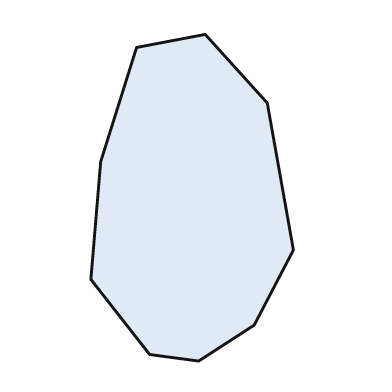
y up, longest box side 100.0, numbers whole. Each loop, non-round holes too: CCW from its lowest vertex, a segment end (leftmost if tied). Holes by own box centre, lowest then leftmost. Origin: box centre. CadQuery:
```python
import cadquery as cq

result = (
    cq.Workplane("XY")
    .moveTo(2.0, -50.0)
    .lineTo(19.0, -39.0)
    .lineTo(31.0, -16.0)
    .lineTo(23.0, 29.0)
    .lineTo(4.0, 50.0)
    .lineTo(-17.0, 46.0)
    .lineTo(-28.0, 11.0)
    .lineTo(-31.0, -25.0)
    .lineTo(-13.0, -48.0)
    .close()
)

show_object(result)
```